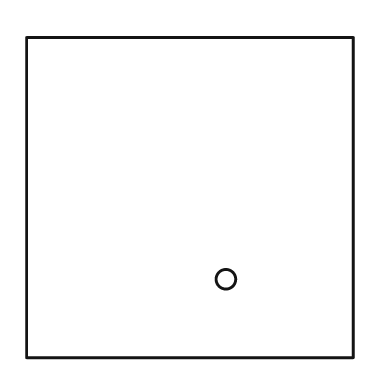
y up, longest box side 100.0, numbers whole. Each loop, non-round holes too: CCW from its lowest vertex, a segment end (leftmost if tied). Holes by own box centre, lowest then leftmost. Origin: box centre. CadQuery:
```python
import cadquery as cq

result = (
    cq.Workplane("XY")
    .moveTo(-50.0, -49.0)
    .lineTo(50.0, -49.0)
    .lineTo(50.0, 49.0)
    .lineTo(-50.0, 49.0)
    .close()
    .moveTo(11.0, -25.0)
    .circle(3.0)
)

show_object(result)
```